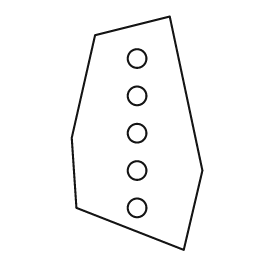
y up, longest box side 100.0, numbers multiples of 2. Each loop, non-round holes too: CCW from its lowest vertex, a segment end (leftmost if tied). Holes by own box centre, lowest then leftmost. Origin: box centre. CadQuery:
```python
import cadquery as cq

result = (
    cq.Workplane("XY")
    .moveTo(20.0, -50.0)
    .lineTo(28.0, -16.0)
    .lineTo(14.0, 50.0)
    .lineTo(-18.0, 42.0)
    .lineTo(-28.0, -2.0)
    .lineTo(-26.0, -32.0)
    .close()
    .moveTo(0.0, -32.0)
    .circle(4.0)
    .moveTo(0.0, -16.0)
    .circle(4.0)
    .moveTo(0.0, 0.0)
    .circle(4.0)
    .moveTo(0.0, 16.0)
    .circle(4.0)
    .moveTo(0.0, 32.0)
    .circle(4.0)
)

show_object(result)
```